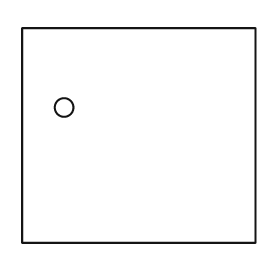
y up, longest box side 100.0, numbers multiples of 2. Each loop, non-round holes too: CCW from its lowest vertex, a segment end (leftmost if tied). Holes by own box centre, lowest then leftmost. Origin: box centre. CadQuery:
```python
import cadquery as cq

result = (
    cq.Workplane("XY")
    .moveTo(-50.0, -46.0)
    .lineTo(50.0, -46.0)
    .lineTo(50.0, 46.0)
    .lineTo(-50.0, 46.0)
    .close()
    .moveTo(-32.0, 12.0)
    .circle(4.0)
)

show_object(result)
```